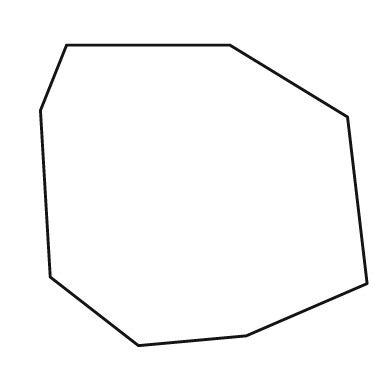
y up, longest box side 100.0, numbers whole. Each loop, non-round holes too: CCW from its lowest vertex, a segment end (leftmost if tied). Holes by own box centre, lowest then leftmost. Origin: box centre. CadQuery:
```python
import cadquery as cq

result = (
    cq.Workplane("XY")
    .moveTo(-20.0, -46.0)
    .lineTo(13.0, -43.0)
    .lineTo(50.0, -27.0)
    .lineTo(44.0, 24.0)
    .lineTo(8.0, 46.0)
    .lineTo(-42.0, 46.0)
    .lineTo(-50.0, 26.0)
    .lineTo(-47.0, -25.0)
    .close()
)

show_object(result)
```